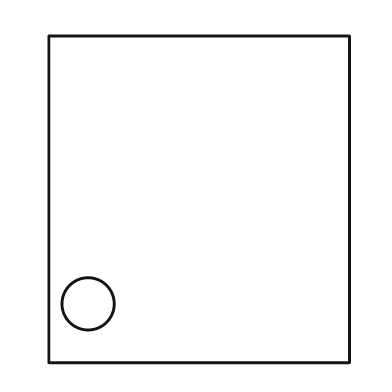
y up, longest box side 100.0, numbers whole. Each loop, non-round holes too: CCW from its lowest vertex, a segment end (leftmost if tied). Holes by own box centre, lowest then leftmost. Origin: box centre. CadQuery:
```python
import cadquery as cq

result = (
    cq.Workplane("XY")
    .moveTo(-46.0, -50.0)
    .lineTo(46.0, -50.0)
    .lineTo(46.0, 50.0)
    .lineTo(-46.0, 50.0)
    .close()
    .moveTo(-34.0, -32.0)
    .circle(8.0)
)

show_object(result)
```